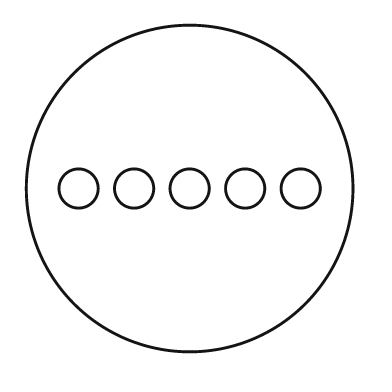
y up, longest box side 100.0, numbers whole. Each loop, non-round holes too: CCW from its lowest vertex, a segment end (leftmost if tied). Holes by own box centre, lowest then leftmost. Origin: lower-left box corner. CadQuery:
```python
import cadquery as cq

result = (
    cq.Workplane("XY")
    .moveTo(50.0, 50.0)
    .circle(50.0)
    .moveTo(16.0, 50.0)
    .circle(6.0)
    .moveTo(33.0, 50.0)
    .circle(6.0)
    .moveTo(50.0, 50.0)
    .circle(6.0)
    .moveTo(67.0, 50.0)
    .circle(6.0)
    .moveTo(84.0, 50.0)
    .circle(6.0)
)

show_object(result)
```